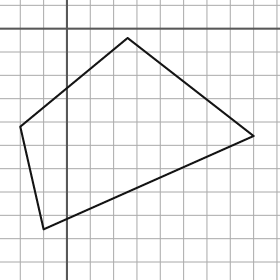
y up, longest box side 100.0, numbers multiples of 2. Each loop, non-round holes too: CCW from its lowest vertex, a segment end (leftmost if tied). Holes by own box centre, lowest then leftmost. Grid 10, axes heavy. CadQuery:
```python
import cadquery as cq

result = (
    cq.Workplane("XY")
    .moveTo(-10.0, -86.0)
    .lineTo(80.0, -46.0)
    .lineTo(26.0, -4.0)
    .lineTo(-20.0, -42.0)
    .close()
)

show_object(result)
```